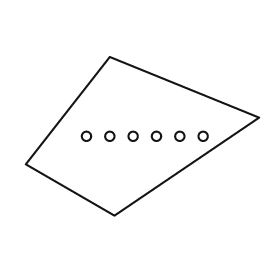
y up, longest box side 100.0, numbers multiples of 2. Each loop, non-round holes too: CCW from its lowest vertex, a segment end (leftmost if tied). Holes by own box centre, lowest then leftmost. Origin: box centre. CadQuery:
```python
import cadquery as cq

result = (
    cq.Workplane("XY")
    .moveTo(-12.0, -34.0)
    .lineTo(50.0, 8.0)
    .lineTo(-14.0, 34.0)
    .lineTo(-50.0, -12.0)
    .close()
    .moveTo(-24.0, 0.0)
    .circle(2.0)
    .moveTo(-14.0, 0.0)
    .circle(2.0)
    .moveTo(-4.0, 0.0)
    .circle(2.0)
    .moveTo(6.0, 0.0)
    .circle(2.0)
    .moveTo(16.0, 0.0)
    .circle(2.0)
    .moveTo(26.0, 0.0)
    .circle(2.0)
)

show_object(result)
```